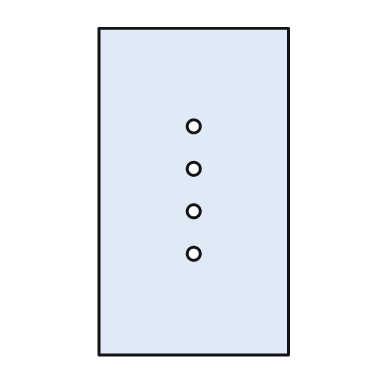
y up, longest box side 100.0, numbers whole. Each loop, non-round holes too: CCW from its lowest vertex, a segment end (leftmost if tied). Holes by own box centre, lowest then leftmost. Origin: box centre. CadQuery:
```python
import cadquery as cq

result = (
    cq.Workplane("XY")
    .moveTo(-29.0, -50.0)
    .lineTo(29.0, -50.0)
    .lineTo(29.0, 50.0)
    .lineTo(-29.0, 50.0)
    .close()
    .moveTo(0.0, -19.0)
    .circle(2.0)
    .moveTo(0.0, -6.0)
    .circle(2.0)
    .moveTo(0.0, 7.0)
    .circle(2.0)
    .moveTo(0.0, 20.0)
    .circle(2.0)
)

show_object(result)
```